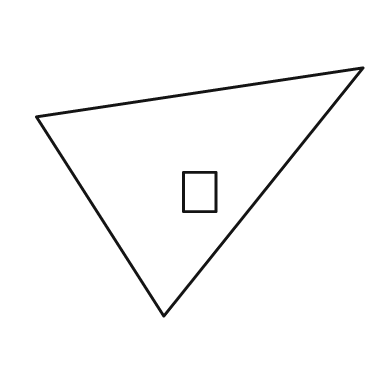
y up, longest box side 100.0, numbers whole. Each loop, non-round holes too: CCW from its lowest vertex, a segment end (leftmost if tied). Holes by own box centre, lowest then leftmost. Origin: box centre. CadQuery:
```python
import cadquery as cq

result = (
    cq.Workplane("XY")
    .moveTo(-11.0, -38.0)
    .lineTo(50.0, 38.0)
    .lineTo(-50.0, 23.0)
    .close()
    .moveTo(-5.0, -6.0)
    .lineTo(5.0, -6.0)
    .lineTo(5.0, 6.0)
    .lineTo(-5.0, 6.0)
    .close()
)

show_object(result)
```